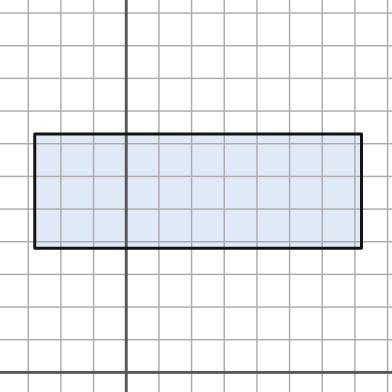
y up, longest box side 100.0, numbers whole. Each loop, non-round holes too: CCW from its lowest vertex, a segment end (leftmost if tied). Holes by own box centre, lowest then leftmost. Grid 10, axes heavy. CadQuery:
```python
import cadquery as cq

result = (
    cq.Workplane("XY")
    .moveTo(-28.0, 38.0)
    .lineTo(72.0, 38.0)
    .lineTo(72.0, 73.0)
    .lineTo(-28.0, 73.0)
    .close()
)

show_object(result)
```